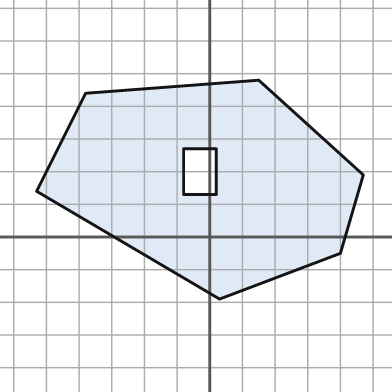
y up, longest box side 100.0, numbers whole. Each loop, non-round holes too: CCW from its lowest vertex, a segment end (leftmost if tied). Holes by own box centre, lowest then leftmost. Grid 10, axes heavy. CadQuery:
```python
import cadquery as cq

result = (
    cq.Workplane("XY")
    .moveTo(3.0, -19.0)
    .lineTo(40.0, -5.0)
    .lineTo(47.0, 19.0)
    .lineTo(15.0, 48.0)
    .lineTo(-38.0, 44.0)
    .lineTo(-53.0, 14.0)
    .close()
    .moveTo(-8.0, 13.0)
    .lineTo(2.0, 13.0)
    .lineTo(2.0, 27.0)
    .lineTo(-8.0, 27.0)
    .close()
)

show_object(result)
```